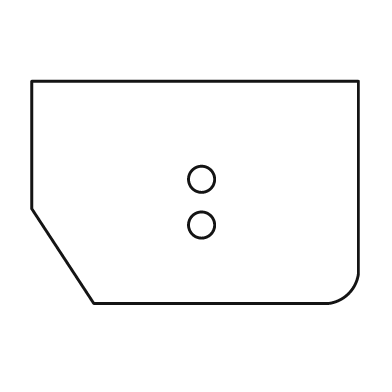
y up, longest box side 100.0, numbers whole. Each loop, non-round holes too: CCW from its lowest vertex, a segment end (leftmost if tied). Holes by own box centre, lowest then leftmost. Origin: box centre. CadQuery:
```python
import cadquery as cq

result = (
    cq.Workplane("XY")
    .moveTo(-31.0, -34.0)
    .lineTo(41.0, -34.0)
    .threePointArc((47.0, -31.0), (50.0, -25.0))
    .lineTo(50.0, 34.0)
    .lineTo(-50.0, 34.0)
    .lineTo(-50.0, -5.0)
    .close()
    .moveTo(2.0, -10.0)
    .circle(4.0)
    .moveTo(2.0, 4.0)
    .circle(4.0)
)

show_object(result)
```